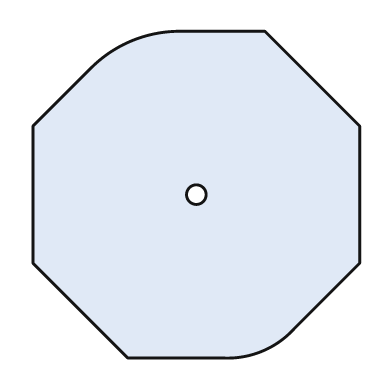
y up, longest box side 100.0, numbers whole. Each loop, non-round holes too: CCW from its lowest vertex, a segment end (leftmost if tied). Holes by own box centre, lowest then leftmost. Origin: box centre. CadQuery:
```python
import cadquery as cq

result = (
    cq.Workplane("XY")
    .moveTo(-21.0, -50.0)
    .lineTo(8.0, -50.0)
    .threePointArc((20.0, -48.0), (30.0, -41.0))
    .lineTo(50.0, -21.0)
    .lineTo(50.0, 21.0)
    .lineTo(21.0, 50.0)
    .lineTo(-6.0, 50.0)
    .threePointArc((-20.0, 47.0), (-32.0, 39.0))
    .lineTo(-50.0, 21.0)
    .lineTo(-50.0, -21.0)
    .close()
    .moveTo(0.0, 0.0)
    .circle(3.0)
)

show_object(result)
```